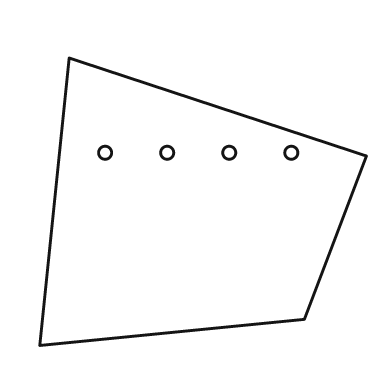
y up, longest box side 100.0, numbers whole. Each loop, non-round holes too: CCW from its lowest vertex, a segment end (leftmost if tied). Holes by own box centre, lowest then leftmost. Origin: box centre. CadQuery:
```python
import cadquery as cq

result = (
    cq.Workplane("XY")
    .moveTo(-50.0, -44.0)
    .lineTo(31.0, -36.0)
    .lineTo(50.0, 14.0)
    .lineTo(-41.0, 44.0)
    .close()
    .moveTo(-30.0, 15.0)
    .circle(2.0)
    .moveTo(-11.0, 15.0)
    .circle(2.0)
    .moveTo(8.0, 15.0)
    .circle(2.0)
    .moveTo(27.0, 15.0)
    .circle(2.0)
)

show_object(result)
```